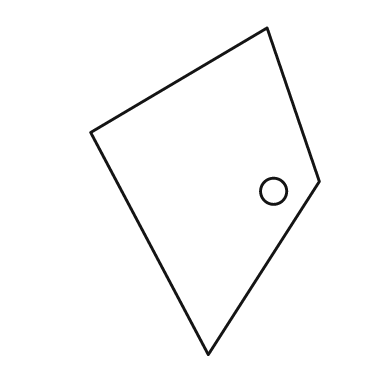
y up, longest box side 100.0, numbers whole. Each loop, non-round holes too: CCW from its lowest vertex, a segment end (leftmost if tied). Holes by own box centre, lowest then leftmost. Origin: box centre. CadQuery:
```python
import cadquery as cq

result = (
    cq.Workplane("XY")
    .moveTo(1.0, -50.0)
    .lineTo(35.0, 3.0)
    .lineTo(19.0, 50.0)
    .lineTo(-35.0, 18.0)
    .close()
    .moveTo(21.0, 0.0)
    .circle(4.0)
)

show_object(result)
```